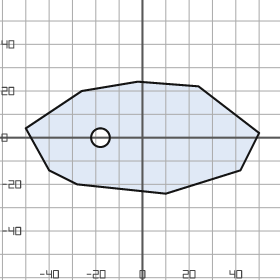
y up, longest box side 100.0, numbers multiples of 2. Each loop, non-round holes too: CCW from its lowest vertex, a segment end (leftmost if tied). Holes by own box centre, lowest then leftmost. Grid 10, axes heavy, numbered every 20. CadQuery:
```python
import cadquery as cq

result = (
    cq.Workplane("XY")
    .moveTo(10.0, -24.0)
    .lineTo(42.0, -14.0)
    .lineTo(50.0, 2.0)
    .lineTo(24.0, 22.0)
    .lineTo(-2.0, 24.0)
    .lineTo(-26.0, 20.0)
    .lineTo(-50.0, 4.0)
    .lineTo(-40.0, -14.0)
    .lineTo(-28.0, -20.0)
    .close()
    .moveTo(-18.0, 0.0)
    .circle(4.0)
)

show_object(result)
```